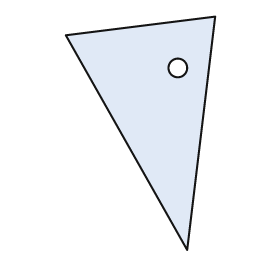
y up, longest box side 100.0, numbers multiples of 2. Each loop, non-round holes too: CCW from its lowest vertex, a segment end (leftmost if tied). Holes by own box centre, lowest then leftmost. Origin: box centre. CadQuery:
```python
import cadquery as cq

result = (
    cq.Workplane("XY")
    .moveTo(20.0, -50.0)
    .lineTo(32.0, 50.0)
    .lineTo(-32.0, 42.0)
    .close()
    .moveTo(16.0, 28.0)
    .circle(4.0)
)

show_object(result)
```